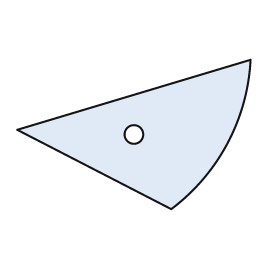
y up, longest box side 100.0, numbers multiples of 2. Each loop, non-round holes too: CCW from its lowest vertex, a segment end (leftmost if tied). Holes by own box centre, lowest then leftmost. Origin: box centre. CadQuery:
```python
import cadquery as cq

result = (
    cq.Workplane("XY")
    .moveTo(16.0, -32.0)
    .threePointArc((40.0, -4.0), (50.0, 32.0))
    .lineTo(-50.0, 2.0)
    .close()
    .moveTo(0.0, 0.0)
    .circle(4.0)
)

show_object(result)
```